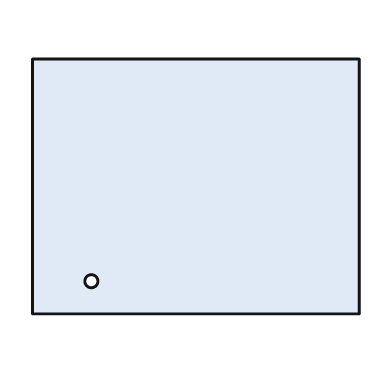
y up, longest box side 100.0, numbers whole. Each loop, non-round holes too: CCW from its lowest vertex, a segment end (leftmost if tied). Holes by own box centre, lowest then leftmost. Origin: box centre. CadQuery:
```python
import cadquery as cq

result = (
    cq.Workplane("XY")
    .moveTo(-50.0, -39.0)
    .lineTo(50.0, -39.0)
    .lineTo(50.0, 39.0)
    .lineTo(-50.0, 39.0)
    .close()
    .moveTo(-32.0, -29.0)
    .circle(2.0)
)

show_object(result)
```